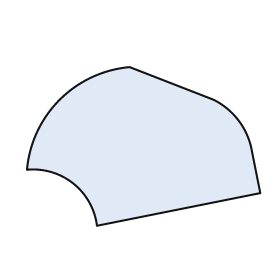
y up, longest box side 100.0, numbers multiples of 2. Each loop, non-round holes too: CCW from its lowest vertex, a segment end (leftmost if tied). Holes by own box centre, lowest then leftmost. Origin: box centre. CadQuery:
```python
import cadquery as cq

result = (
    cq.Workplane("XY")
    .moveTo(-20.0, -34.0)
    .lineTo(50.0, -20.0)
    .lineTo(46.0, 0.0)
    .threePointArc((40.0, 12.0), (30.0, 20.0))
    .lineTo(-6.0, 34.0)
    .threePointArc((-36.0, 20.0), (-50.0, -10.0))
    .threePointArc((-30.0, -16.0), (-20.0, -34.0))
    .close()
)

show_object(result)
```